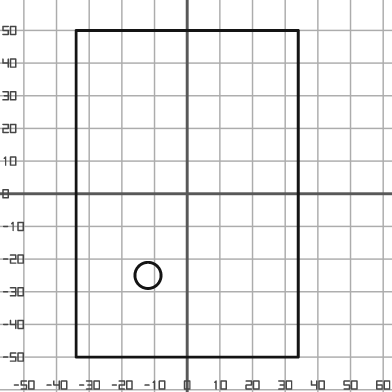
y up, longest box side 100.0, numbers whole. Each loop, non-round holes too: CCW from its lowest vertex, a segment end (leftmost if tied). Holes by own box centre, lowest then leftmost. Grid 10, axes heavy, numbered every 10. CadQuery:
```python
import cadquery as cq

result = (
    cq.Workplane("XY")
    .moveTo(-34.0, -50.0)
    .lineTo(34.0, -50.0)
    .lineTo(34.0, 50.0)
    .lineTo(-34.0, 50.0)
    .close()
    .moveTo(-12.0, -25.0)
    .circle(4.0)
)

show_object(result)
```